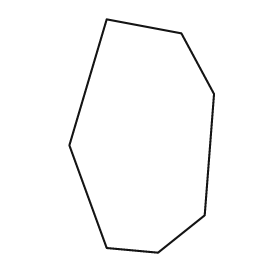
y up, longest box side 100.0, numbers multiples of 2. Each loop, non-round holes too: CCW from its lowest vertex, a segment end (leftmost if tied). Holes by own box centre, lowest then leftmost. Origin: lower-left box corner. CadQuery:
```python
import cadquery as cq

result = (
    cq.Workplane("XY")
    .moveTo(38.0, 0.0)
    .lineTo(58.0, 16.0)
    .lineTo(62.0, 68.0)
    .lineTo(48.0, 94.0)
    .lineTo(16.0, 100.0)
    .lineTo(0.0, 46.0)
    .lineTo(16.0, 2.0)
    .close()
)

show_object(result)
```